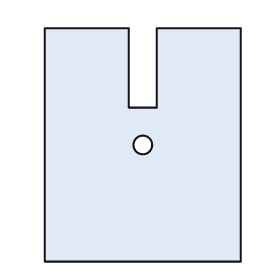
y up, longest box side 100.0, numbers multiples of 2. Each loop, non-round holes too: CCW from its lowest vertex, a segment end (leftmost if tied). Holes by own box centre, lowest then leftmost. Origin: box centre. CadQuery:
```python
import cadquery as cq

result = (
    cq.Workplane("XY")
    .moveTo(-42.0, -50.0)
    .lineTo(42.0, -50.0)
    .lineTo(42.0, 50.0)
    .lineTo(6.0, 50.0)
    .lineTo(6.0, 16.0)
    .lineTo(-6.0, 16.0)
    .lineTo(-6.0, 50.0)
    .lineTo(-42.0, 50.0)
    .close()
    .moveTo(0.0, 0.0)
    .circle(4.0)
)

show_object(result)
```